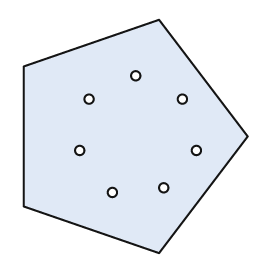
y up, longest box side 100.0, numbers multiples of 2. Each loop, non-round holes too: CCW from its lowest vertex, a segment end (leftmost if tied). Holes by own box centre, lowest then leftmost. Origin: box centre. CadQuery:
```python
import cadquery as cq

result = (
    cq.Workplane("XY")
    .moveTo(10.0, -50.0)
    .lineTo(48.0, 0.0)
    .lineTo(10.0, 50.0)
    .lineTo(-48.0, 30.0)
    .lineTo(-48.0, -30.0)
    .close()
    .moveTo(-10.0, -24.0)
    .circle(2.0)
    .moveTo(12.0, -22.0)
    .circle(2.0)
    .moveTo(-24.0, -6.0)
    .circle(2.0)
    .moveTo(26.0, -6.0)
    .circle(2.0)
    .moveTo(-20.0, 16.0)
    .circle(2.0)
    .moveTo(20.0, 16.0)
    .circle(2.0)
    .moveTo(0.0, 26.0)
    .circle(2.0)
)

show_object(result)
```